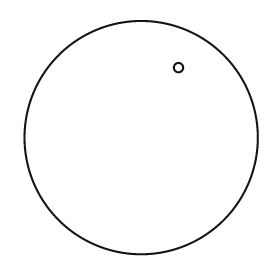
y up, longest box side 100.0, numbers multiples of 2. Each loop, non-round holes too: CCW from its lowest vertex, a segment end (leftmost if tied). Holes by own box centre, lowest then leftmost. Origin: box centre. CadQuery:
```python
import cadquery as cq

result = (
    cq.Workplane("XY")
    .moveTo(0.0, 0.0)
    .circle(50.0)
    .moveTo(16.0, 30.0)
    .circle(2.0)
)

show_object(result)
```